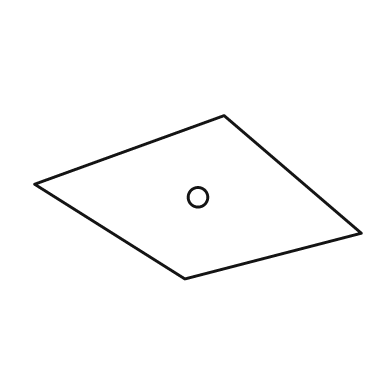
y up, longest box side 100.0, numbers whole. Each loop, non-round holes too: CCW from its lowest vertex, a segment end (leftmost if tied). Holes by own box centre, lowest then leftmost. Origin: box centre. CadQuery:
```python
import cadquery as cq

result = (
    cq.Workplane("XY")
    .moveTo(-4.0, -25.0)
    .lineTo(50.0, -11.0)
    .lineTo(8.0, 25.0)
    .lineTo(-50.0, 4.0)
    .close()
    .moveTo(0.0, 0.0)
    .circle(3.0)
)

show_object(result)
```